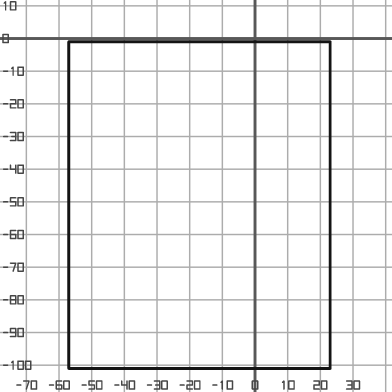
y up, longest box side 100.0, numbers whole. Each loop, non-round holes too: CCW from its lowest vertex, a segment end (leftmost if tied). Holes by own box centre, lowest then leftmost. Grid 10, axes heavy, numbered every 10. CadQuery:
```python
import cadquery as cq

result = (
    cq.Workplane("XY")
    .moveTo(-57.0, -101.0)
    .lineTo(23.0, -101.0)
    .lineTo(23.0, -1.0)
    .lineTo(-57.0, -1.0)
    .close()
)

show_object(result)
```